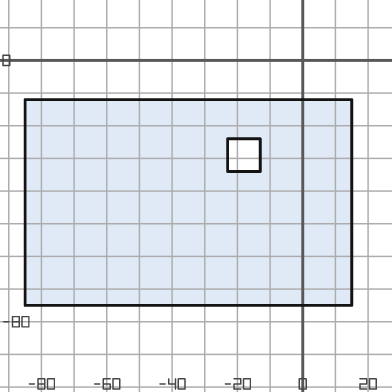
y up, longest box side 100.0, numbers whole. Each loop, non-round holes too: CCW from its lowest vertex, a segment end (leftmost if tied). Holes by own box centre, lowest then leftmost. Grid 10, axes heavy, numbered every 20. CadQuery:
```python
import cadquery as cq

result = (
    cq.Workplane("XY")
    .moveTo(-85.0, -75.0)
    .lineTo(15.0, -75.0)
    .lineTo(15.0, -12.0)
    .lineTo(-85.0, -12.0)
    .close()
    .moveTo(-23.0, -34.0)
    .lineTo(-13.0, -34.0)
    .lineTo(-13.0, -24.0)
    .lineTo(-23.0, -24.0)
    .close()
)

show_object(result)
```